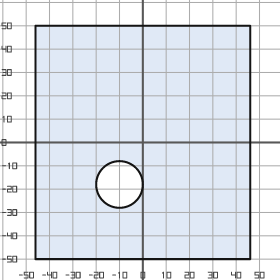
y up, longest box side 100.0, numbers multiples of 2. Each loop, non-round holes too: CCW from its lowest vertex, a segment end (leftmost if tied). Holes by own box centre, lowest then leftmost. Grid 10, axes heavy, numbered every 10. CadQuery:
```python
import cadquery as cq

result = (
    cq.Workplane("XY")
    .moveTo(-46.0, -50.0)
    .lineTo(46.0, -50.0)
    .lineTo(46.0, 50.0)
    .lineTo(-46.0, 50.0)
    .close()
    .moveTo(-10.0, -18.0)
    .circle(10.0)
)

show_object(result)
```